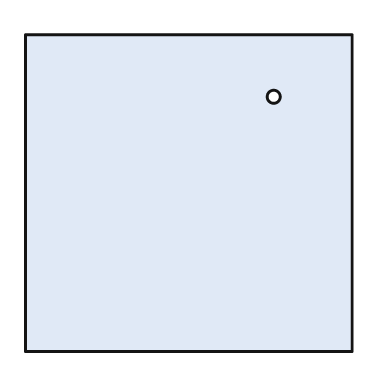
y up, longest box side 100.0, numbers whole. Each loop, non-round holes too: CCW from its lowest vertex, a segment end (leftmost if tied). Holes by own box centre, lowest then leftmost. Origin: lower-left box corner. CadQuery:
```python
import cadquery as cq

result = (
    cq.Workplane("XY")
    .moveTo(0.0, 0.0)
    .lineTo(100.0, 0.0)
    .lineTo(100.0, 97.0)
    .lineTo(0.0, 97.0)
    .close()
    .moveTo(76.0, 78.0)
    .circle(2.0)
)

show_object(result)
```